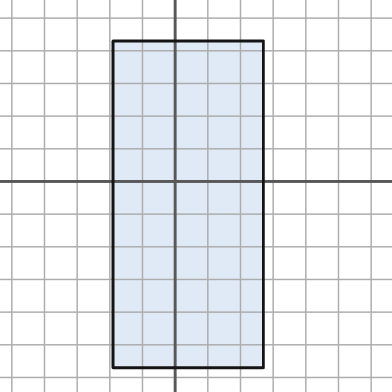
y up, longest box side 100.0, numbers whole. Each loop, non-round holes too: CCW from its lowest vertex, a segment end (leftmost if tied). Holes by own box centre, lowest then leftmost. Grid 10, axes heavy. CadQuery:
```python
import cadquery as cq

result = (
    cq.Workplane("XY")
    .moveTo(-19.0, -57.0)
    .lineTo(27.0, -57.0)
    .lineTo(27.0, 43.0)
    .lineTo(-19.0, 43.0)
    .close()
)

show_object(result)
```